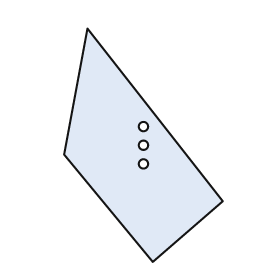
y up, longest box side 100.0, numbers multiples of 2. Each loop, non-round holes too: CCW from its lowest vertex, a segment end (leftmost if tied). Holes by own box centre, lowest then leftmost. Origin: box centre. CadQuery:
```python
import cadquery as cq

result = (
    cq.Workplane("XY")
    .moveTo(4.0, -50.0)
    .lineTo(34.0, -24.0)
    .lineTo(-24.0, 50.0)
    .lineTo(-34.0, -4.0)
    .close()
    .moveTo(0.0, -8.0)
    .circle(2.0)
    .moveTo(0.0, 0.0)
    .circle(2.0)
    .moveTo(0.0, 8.0)
    .circle(2.0)
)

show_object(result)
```